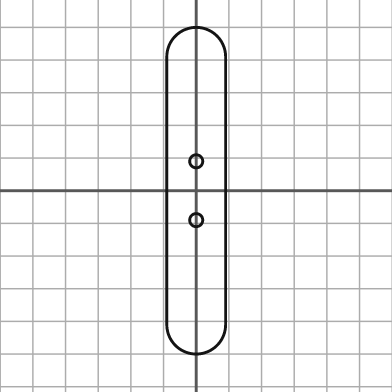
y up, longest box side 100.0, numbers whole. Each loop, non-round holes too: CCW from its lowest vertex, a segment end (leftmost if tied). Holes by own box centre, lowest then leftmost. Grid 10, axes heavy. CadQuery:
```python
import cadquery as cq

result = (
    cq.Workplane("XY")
    .moveTo(-9.0, -41.0)
    .threePointArc((0.0, -50.0), (9.0, -41.0))
    .lineTo(9.0, 41.0)
    .threePointArc((0.0, 50.0), (-9.0, 41.0))
    .close()
    .moveTo(0.0, -9.0)
    .circle(2.0)
    .moveTo(0.0, 9.0)
    .circle(2.0)
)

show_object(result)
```